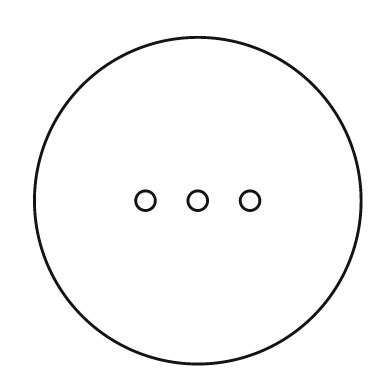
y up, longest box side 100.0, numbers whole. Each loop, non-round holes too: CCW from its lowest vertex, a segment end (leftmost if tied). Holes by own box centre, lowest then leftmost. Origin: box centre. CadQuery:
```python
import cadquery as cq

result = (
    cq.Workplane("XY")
    .moveTo(0.0, 0.0)
    .circle(50.0)
    .moveTo(-16.0, 0.0)
    .circle(3.0)
    .moveTo(0.0, 0.0)
    .circle(3.0)
    .moveTo(16.0, 0.0)
    .circle(3.0)
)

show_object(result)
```